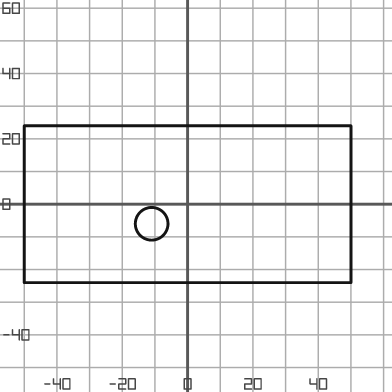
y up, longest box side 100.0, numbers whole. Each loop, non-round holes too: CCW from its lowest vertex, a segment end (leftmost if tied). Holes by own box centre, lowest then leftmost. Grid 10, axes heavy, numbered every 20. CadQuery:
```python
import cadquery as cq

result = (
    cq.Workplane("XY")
    .moveTo(-50.0, -24.0)
    .lineTo(50.0, -24.0)
    .lineTo(50.0, 24.0)
    .lineTo(-50.0, 24.0)
    .close()
    .moveTo(-11.0, -6.0)
    .circle(5.0)
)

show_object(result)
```